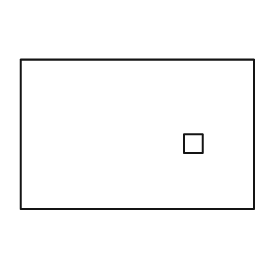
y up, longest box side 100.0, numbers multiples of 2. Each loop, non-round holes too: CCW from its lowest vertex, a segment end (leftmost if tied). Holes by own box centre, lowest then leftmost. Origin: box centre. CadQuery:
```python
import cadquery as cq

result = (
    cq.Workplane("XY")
    .moveTo(-50.0, -32.0)
    .lineTo(50.0, -32.0)
    .lineTo(50.0, 32.0)
    .lineTo(-50.0, 32.0)
    .close()
    .moveTo(20.0, -8.0)
    .lineTo(28.0, -8.0)
    .lineTo(28.0, 0.0)
    .lineTo(20.0, 0.0)
    .close()
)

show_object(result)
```